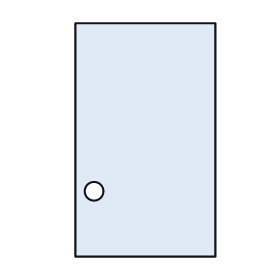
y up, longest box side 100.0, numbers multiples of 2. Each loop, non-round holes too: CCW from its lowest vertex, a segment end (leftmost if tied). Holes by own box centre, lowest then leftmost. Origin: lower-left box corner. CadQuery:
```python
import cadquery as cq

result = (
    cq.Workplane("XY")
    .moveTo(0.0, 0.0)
    .lineTo(60.0, 0.0)
    .lineTo(60.0, 100.0)
    .lineTo(0.0, 100.0)
    .close()
    .moveTo(8.0, 28.0)
    .circle(4.0)
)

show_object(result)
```